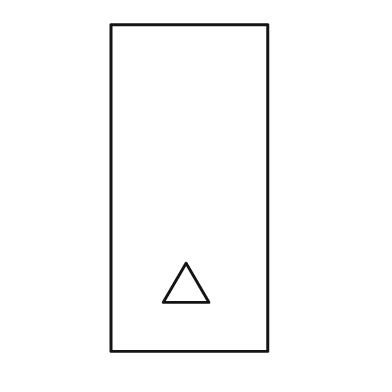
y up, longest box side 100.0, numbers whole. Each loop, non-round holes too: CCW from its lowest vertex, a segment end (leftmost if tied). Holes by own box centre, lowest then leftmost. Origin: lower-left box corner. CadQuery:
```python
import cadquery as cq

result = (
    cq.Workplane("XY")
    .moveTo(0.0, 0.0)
    .lineTo(48.0, 0.0)
    .lineTo(48.0, 100.0)
    .lineTo(0.0, 100.0)
    .close()
    .moveTo(16.0, 15.0)
    .lineTo(30.0, 15.0)
    .lineTo(23.0, 27.0)
    .close()
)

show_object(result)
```